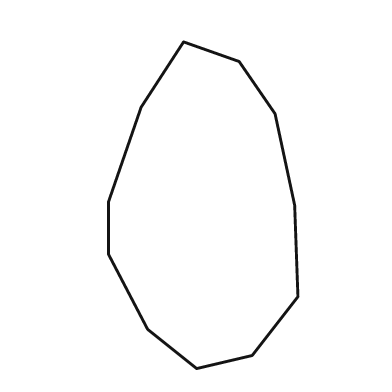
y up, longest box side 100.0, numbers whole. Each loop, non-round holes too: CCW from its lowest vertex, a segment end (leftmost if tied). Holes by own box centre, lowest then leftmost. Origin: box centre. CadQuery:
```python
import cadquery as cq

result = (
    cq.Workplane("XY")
    .moveTo(-2.0, -50.0)
    .lineTo(15.0, -46.0)
    .lineTo(29.0, -28.0)
    .lineTo(28.0, 0.0)
    .lineTo(22.0, 28.0)
    .lineTo(11.0, 44.0)
    .lineTo(-6.0, 50.0)
    .lineTo(-19.0, 30.0)
    .lineTo(-29.0, 1.0)
    .lineTo(-29.0, -15.0)
    .lineTo(-17.0, -38.0)
    .close()
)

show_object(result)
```